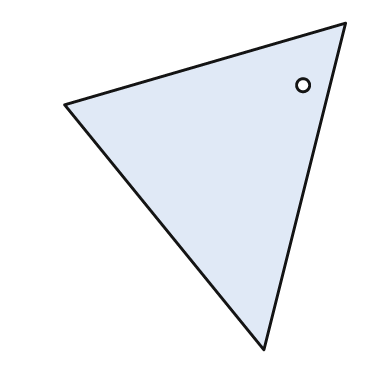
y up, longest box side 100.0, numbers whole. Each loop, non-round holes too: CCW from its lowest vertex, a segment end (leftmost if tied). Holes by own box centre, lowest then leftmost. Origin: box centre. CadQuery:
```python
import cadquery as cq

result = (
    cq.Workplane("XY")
    .moveTo(18.0, -50.0)
    .lineTo(43.0, 50.0)
    .lineTo(-43.0, 25.0)
    .close()
    .moveTo(30.0, 31.0)
    .circle(2.0)
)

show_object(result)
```